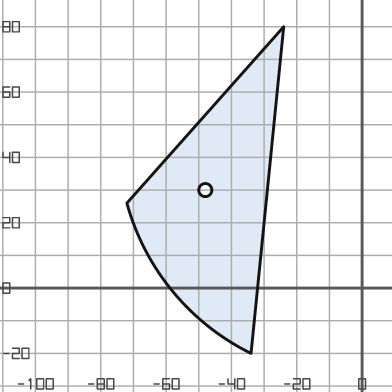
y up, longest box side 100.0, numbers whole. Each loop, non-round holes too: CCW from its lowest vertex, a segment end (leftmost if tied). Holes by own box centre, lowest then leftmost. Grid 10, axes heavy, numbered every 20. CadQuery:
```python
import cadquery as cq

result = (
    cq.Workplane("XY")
    .moveTo(-34.0, -20.0)
    .lineTo(-24.0, 80.0)
    .lineTo(-72.0, 26.0)
    .threePointArc((-58.0, -1.0), (-34.0, -20.0))
    .close()
    .moveTo(-48.0, 30.0)
    .circle(2.0)
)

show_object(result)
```